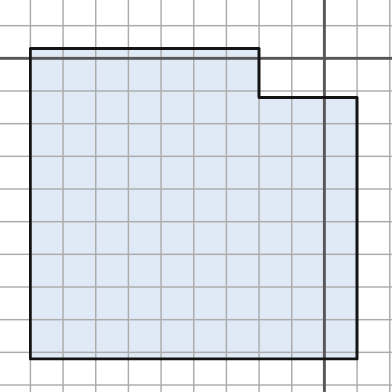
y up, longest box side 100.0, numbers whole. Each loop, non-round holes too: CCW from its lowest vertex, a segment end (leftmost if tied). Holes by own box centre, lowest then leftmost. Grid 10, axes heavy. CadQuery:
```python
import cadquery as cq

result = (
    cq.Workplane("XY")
    .moveTo(-90.0, -92.0)
    .lineTo(10.0, -92.0)
    .lineTo(10.0, -12.0)
    .lineTo(-20.0, -12.0)
    .lineTo(-20.0, 3.0)
    .lineTo(-90.0, 3.0)
    .close()
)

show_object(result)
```